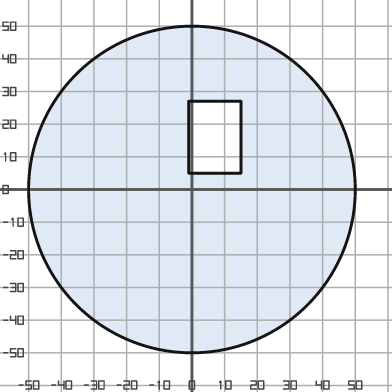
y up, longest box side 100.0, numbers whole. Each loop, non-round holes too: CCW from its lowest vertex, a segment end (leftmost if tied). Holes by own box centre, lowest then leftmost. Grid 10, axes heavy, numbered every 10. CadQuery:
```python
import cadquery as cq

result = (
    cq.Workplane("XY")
    .moveTo(0.0, 0.0)
    .circle(50.0)
    .moveTo(-1.0, 5.0)
    .lineTo(15.0, 5.0)
    .lineTo(15.0, 27.0)
    .lineTo(-1.0, 27.0)
    .close()
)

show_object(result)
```